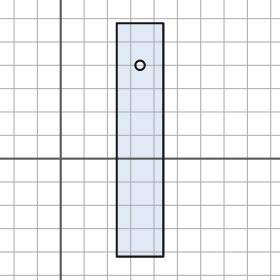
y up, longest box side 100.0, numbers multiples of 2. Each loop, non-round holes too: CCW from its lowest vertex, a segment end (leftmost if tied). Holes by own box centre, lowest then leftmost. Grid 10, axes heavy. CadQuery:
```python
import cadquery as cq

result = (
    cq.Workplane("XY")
    .moveTo(24.0, -42.0)
    .lineTo(44.0, -42.0)
    .lineTo(44.0, 58.0)
    .lineTo(24.0, 58.0)
    .close()
    .moveTo(34.0, 40.0)
    .circle(2.0)
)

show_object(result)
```